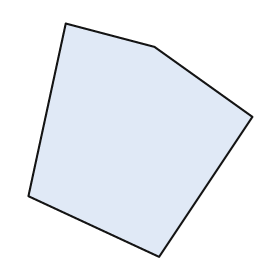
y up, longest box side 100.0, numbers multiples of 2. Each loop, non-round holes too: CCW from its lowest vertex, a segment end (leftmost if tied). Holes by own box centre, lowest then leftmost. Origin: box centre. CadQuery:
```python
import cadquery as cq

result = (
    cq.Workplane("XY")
    .moveTo(8.0, -50.0)
    .lineTo(48.0, 10.0)
    .lineTo(6.0, 40.0)
    .lineTo(-32.0, 50.0)
    .lineTo(-48.0, -24.0)
    .close()
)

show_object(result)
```